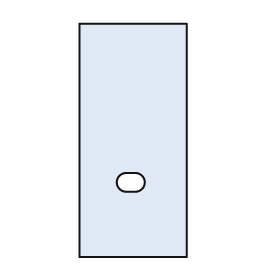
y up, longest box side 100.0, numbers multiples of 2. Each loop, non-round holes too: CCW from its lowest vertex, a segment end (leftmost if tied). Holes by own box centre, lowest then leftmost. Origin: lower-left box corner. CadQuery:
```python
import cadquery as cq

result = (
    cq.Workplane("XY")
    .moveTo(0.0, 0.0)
    .lineTo(46.0, 0.0)
    .lineTo(46.0, 100.0)
    .lineTo(0.0, 100.0)
    .close()
    .moveTo(20.0, 28.0)
    .lineTo(24.0, 28.0)
    .threePointArc((28.0, 32.0), (24.0, 36.0))
    .lineTo(20.0, 36.0)
    .threePointArc((16.0, 32.0), (20.0, 28.0))
    .close()
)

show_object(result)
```